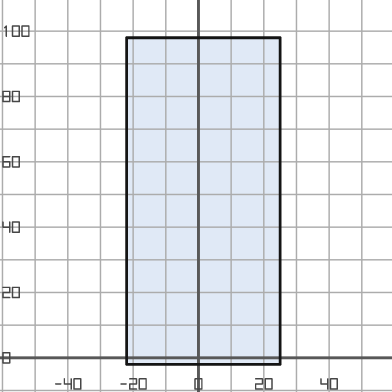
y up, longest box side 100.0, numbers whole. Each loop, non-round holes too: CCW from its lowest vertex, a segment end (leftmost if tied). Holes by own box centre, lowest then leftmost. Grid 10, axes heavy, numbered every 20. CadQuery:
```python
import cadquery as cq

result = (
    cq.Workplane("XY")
    .moveTo(-22.0, -2.0)
    .lineTo(25.0, -2.0)
    .lineTo(25.0, 98.0)
    .lineTo(-22.0, 98.0)
    .close()
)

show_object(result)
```